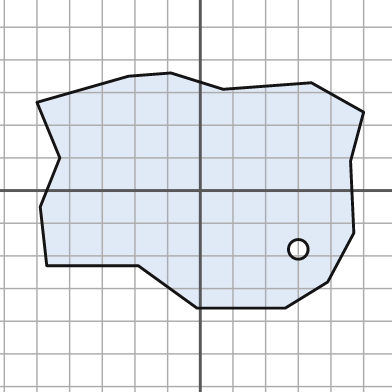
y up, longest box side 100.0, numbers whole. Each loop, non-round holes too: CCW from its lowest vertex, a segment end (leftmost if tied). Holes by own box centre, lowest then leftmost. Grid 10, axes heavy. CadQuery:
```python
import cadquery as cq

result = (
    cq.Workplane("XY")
    .moveTo(-1.0, -36.0)
    .lineTo(26.0, -36.0)
    .lineTo(39.0, -28.0)
    .lineTo(47.0, -13.0)
    .lineTo(46.0, 9.0)
    .lineTo(50.0, 24.0)
    .lineTo(34.0, 33.0)
    .lineTo(7.0, 31.0)
    .lineTo(-9.0, 36.0)
    .lineTo(-22.0, 35.0)
    .lineTo(-50.0, 27.0)
    .lineTo(-43.0, 10.0)
    .lineTo(-49.0, -5.0)
    .lineTo(-47.0, -23.0)
    .lineTo(-19.0, -23.0)
    .close()
    .moveTo(30.0, -18.0)
    .circle(3.0)
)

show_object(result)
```